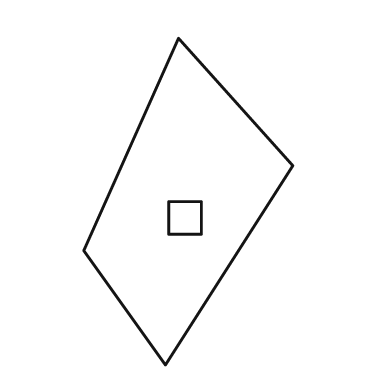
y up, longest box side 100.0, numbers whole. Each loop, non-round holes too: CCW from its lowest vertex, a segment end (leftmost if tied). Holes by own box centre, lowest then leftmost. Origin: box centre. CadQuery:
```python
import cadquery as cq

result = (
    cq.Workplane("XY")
    .moveTo(-7.0, -50.0)
    .lineTo(32.0, 11.0)
    .lineTo(-3.0, 50.0)
    .lineTo(-32.0, -15.0)
    .close()
    .moveTo(-6.0, -10.0)
    .lineTo(4.0, -10.0)
    .lineTo(4.0, 0.0)
    .lineTo(-6.0, 0.0)
    .close()
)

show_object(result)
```